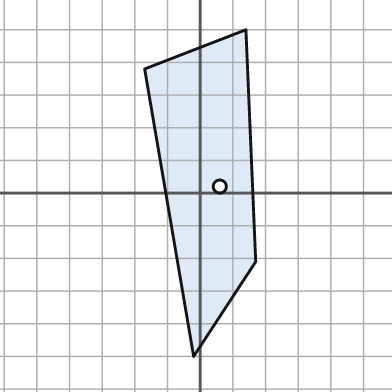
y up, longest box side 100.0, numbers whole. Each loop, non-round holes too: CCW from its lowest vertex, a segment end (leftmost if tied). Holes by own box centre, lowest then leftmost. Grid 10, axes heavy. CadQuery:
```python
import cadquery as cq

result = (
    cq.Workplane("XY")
    .moveTo(-2.0, -50.0)
    .lineTo(17.0, -21.0)
    .lineTo(14.0, 50.0)
    .lineTo(-17.0, 38.0)
    .close()
    .moveTo(6.0, 2.0)
    .circle(2.0)
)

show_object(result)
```